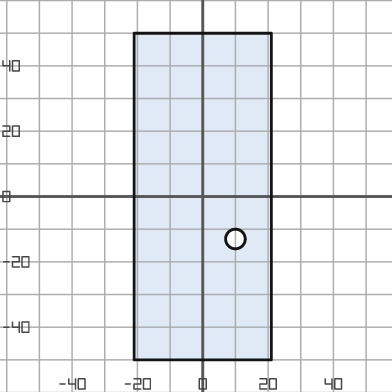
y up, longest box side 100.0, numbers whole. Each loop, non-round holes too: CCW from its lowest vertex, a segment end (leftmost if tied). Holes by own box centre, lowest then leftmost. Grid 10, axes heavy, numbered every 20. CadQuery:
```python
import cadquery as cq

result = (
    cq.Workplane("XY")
    .moveTo(-21.0, -50.0)
    .lineTo(21.0, -50.0)
    .lineTo(21.0, 50.0)
    .lineTo(-21.0, 50.0)
    .close()
    .moveTo(10.0, -13.0)
    .circle(3.0)
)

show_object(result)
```